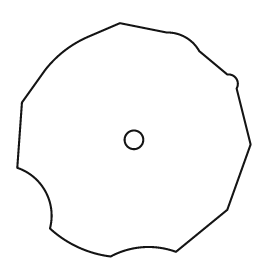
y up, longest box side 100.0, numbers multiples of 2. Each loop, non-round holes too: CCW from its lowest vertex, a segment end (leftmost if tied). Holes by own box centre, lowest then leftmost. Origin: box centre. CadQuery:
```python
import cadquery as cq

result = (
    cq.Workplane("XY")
    .moveTo(-10.0, -50.0)
    .threePointArc((4.0, -46.0), (18.0, -48.0))
    .lineTo(40.0, -30.0)
    .lineTo(50.0, -2.0)
    .lineTo(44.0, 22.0)
    .threePointArc((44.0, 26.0), (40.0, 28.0))
    .lineTo(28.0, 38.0)
    .threePointArc((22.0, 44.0), (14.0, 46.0))
    .lineTo(-6.0, 50.0)
    .lineTo(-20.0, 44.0)
    .threePointArc((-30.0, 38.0), (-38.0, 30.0))
    .lineTo(-48.0, 16.0)
    .lineTo(-50.0, -12.0)
    .threePointArc((-38.0, -22.0), (-36.0, -38.0))
    .threePointArc((-24.0, -46.0), (-10.0, -50.0))
    .close()
    .moveTo(0.0, 0.0)
    .circle(4.0)
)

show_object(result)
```